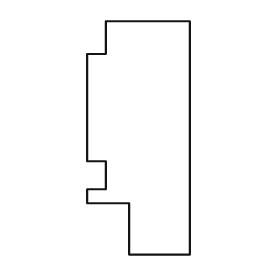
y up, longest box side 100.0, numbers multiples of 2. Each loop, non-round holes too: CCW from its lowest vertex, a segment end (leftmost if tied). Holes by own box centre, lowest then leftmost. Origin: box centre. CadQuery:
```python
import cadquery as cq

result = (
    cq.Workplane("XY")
    .moveTo(-4.0, -50.0)
    .lineTo(22.0, -50.0)
    .lineTo(22.0, 50.0)
    .lineTo(-14.0, 50.0)
    .lineTo(-14.0, 36.0)
    .lineTo(-22.0, 36.0)
    .lineTo(-22.0, -10.0)
    .lineTo(-14.0, -10.0)
    .lineTo(-14.0, -22.0)
    .lineTo(-22.0, -22.0)
    .lineTo(-22.0, -28.0)
    .lineTo(-4.0, -28.0)
    .close()
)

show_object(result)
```